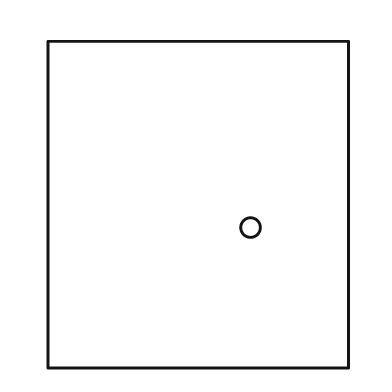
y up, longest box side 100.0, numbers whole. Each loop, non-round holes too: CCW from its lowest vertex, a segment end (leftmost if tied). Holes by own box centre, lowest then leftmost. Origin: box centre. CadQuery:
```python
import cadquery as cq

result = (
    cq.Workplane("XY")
    .moveTo(-46.0, -50.0)
    .lineTo(46.0, -50.0)
    .lineTo(46.0, 50.0)
    .lineTo(-46.0, 50.0)
    .close()
    .moveTo(16.0, -7.0)
    .circle(3.0)
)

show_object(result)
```